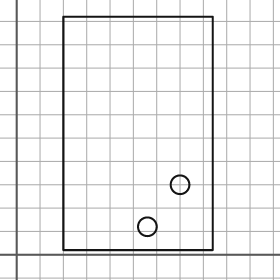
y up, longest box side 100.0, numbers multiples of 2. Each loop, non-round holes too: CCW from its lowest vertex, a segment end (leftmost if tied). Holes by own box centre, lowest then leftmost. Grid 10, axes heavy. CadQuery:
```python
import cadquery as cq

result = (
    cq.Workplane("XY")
    .moveTo(20.0, 2.0)
    .lineTo(84.0, 2.0)
    .lineTo(84.0, 102.0)
    .lineTo(20.0, 102.0)
    .close()
    .moveTo(56.0, 12.0)
    .circle(4.0)
    .moveTo(70.0, 30.0)
    .circle(4.0)
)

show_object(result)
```